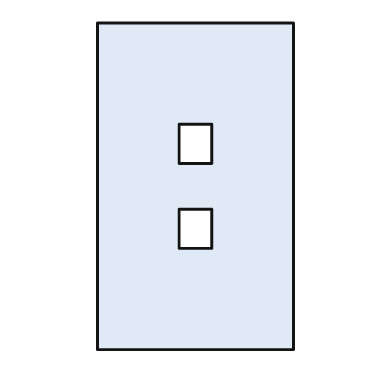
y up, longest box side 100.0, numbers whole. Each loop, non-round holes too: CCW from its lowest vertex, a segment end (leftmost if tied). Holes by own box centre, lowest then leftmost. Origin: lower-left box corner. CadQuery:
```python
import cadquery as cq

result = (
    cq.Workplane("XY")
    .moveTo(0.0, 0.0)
    .lineTo(60.0, 0.0)
    .lineTo(60.0, 100.0)
    .lineTo(0.0, 100.0)
    .close()
    .moveTo(25.0, 31.0)
    .lineTo(35.0, 31.0)
    .lineTo(35.0, 43.0)
    .lineTo(25.0, 43.0)
    .close()
    .moveTo(25.0, 57.0)
    .lineTo(35.0, 57.0)
    .lineTo(35.0, 69.0)
    .lineTo(25.0, 69.0)
    .close()
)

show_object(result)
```